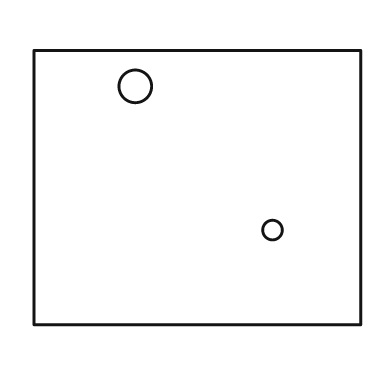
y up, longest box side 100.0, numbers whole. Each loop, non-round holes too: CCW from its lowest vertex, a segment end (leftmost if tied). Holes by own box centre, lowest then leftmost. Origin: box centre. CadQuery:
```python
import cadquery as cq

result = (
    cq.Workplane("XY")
    .moveTo(-50.0, -42.0)
    .lineTo(50.0, -42.0)
    .lineTo(50.0, 42.0)
    .lineTo(-50.0, 42.0)
    .close()
    .moveTo(23.0, -13.0)
    .circle(3.0)
    .moveTo(-19.0, 31.0)
    .circle(5.0)
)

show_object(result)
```